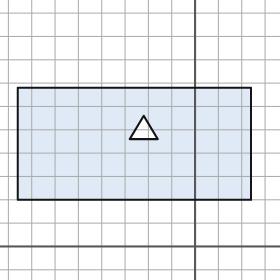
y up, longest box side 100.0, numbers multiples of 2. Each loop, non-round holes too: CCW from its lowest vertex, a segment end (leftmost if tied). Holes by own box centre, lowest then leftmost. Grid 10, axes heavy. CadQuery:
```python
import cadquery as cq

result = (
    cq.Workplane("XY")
    .moveTo(-76.0, 20.0)
    .lineTo(24.0, 20.0)
    .lineTo(24.0, 68.0)
    .lineTo(-76.0, 68.0)
    .close()
    .moveTo(-28.0, 46.0)
    .lineTo(-16.0, 46.0)
    .lineTo(-22.0, 56.0)
    .close()
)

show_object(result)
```